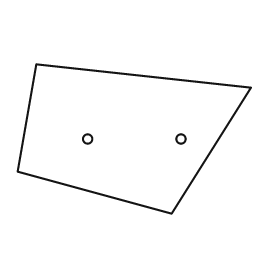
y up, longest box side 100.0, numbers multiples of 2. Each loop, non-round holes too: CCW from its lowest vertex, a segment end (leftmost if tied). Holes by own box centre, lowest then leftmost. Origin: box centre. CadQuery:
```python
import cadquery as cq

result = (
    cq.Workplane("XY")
    .moveTo(16.0, -32.0)
    .lineTo(50.0, 22.0)
    .lineTo(-42.0, 32.0)
    .lineTo(-50.0, -14.0)
    .close()
    .moveTo(-20.0, 0.0)
    .circle(2.0)
    .moveTo(20.0, 0.0)
    .circle(2.0)
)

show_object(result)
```